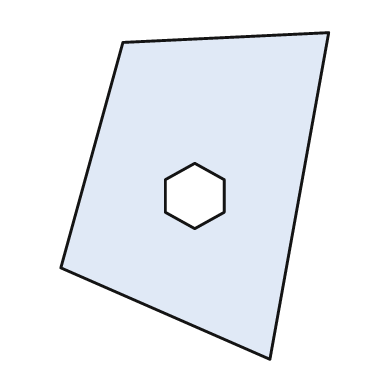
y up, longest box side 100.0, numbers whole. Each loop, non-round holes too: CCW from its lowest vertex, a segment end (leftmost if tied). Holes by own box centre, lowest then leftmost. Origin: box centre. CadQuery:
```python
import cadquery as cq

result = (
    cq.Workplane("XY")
    .moveTo(23.0, -50.0)
    .lineTo(41.0, 50.0)
    .lineTo(-22.0, 47.0)
    .lineTo(-41.0, -22.0)
    .close()
    .moveTo(0.0, -10.0)
    .lineTo(9.0, -5.0)
    .lineTo(9.0, 5.0)
    .lineTo(0.0, 10.0)
    .lineTo(-9.0, 5.0)
    .lineTo(-9.0, -5.0)
    .close()
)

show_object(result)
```